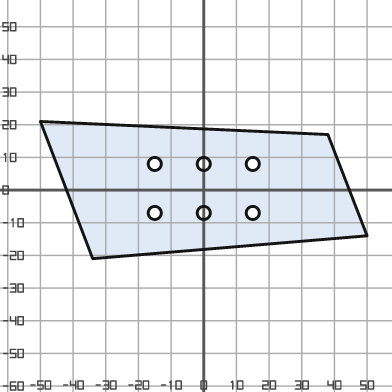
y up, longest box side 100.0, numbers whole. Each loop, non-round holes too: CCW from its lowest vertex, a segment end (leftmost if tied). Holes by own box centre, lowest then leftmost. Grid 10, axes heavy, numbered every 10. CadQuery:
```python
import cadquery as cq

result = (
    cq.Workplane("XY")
    .moveTo(-34.0, -21.0)
    .lineTo(50.0, -14.0)
    .lineTo(38.0, 17.0)
    .lineTo(-50.0, 21.0)
    .close()
    .moveTo(-15.0, -7.0)
    .circle(2.0)
    .moveTo(0.0, -7.0)
    .circle(2.0)
    .moveTo(15.0, -7.0)
    .circle(2.0)
    .moveTo(-15.0, 8.0)
    .circle(2.0)
    .moveTo(0.0, 8.0)
    .circle(2.0)
    .moveTo(15.0, 8.0)
    .circle(2.0)
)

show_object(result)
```